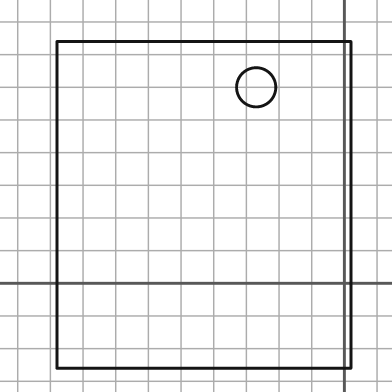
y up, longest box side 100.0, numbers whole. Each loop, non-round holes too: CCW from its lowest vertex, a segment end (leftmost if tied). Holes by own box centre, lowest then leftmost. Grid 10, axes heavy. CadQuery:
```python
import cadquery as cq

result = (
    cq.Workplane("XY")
    .moveTo(-88.0, -26.0)
    .lineTo(2.0, -26.0)
    .lineTo(2.0, 74.0)
    .lineTo(-88.0, 74.0)
    .close()
    .moveTo(-27.0, 60.0)
    .circle(6.0)
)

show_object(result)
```